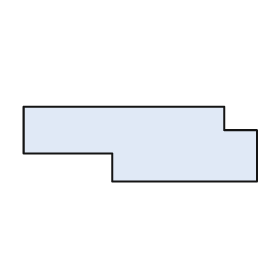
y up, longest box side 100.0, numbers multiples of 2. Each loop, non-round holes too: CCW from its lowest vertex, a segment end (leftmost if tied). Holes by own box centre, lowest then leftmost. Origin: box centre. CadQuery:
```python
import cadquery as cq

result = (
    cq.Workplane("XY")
    .moveTo(-12.0, -16.0)
    .lineTo(50.0, -16.0)
    .lineTo(50.0, 6.0)
    .lineTo(36.0, 6.0)
    .lineTo(36.0, 16.0)
    .lineTo(-50.0, 16.0)
    .lineTo(-50.0, -4.0)
    .lineTo(-12.0, -4.0)
    .close()
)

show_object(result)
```